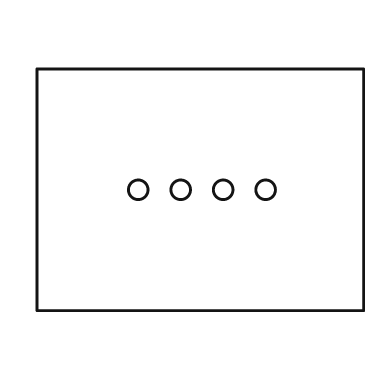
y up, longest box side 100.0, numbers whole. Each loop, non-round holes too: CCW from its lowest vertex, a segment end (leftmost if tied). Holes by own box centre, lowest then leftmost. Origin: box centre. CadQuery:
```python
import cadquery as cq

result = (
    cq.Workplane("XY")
    .moveTo(-50.0, -37.0)
    .lineTo(50.0, -37.0)
    .lineTo(50.0, 37.0)
    .lineTo(-50.0, 37.0)
    .close()
    .moveTo(-19.0, 0.0)
    .circle(3.0)
    .moveTo(-6.0, 0.0)
    .circle(3.0)
    .moveTo(7.0, 0.0)
    .circle(3.0)
    .moveTo(20.0, 0.0)
    .circle(3.0)
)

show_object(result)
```